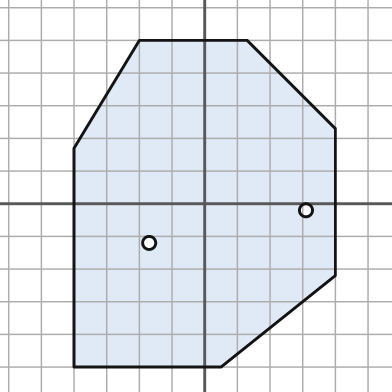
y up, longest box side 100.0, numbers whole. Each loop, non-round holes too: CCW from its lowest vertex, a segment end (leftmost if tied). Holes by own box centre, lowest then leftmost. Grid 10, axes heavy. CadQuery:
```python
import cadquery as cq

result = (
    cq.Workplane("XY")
    .moveTo(-40.0, -50.0)
    .lineTo(5.0, -50.0)
    .lineTo(40.0, -22.0)
    .lineTo(40.0, 23.0)
    .lineTo(13.0, 50.0)
    .lineTo(-20.0, 50.0)
    .lineTo(-40.0, 17.0)
    .close()
    .moveTo(-17.0, -12.0)
    .circle(2.0)
    .moveTo(31.0, -2.0)
    .circle(2.0)
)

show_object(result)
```